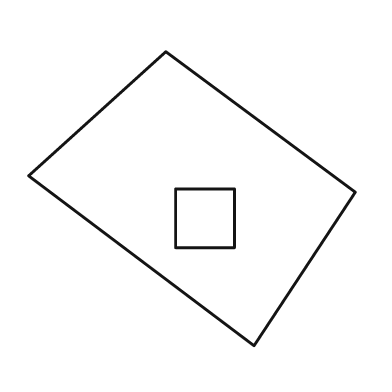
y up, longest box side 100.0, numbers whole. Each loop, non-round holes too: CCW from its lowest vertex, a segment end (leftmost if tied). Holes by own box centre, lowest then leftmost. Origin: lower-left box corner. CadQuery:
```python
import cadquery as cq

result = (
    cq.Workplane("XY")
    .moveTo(69.0, 0.0)
    .lineTo(100.0, 47.0)
    .lineTo(42.0, 90.0)
    .lineTo(0.0, 52.0)
    .close()
    .moveTo(45.0, 30.0)
    .lineTo(63.0, 30.0)
    .lineTo(63.0, 48.0)
    .lineTo(45.0, 48.0)
    .close()
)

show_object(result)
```